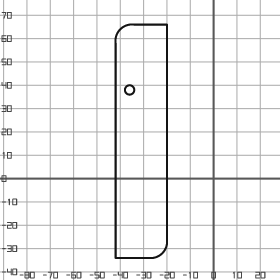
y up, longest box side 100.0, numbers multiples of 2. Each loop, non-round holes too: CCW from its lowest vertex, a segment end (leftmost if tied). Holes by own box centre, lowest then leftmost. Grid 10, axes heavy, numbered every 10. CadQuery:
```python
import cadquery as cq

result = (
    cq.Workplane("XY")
    .moveTo(-42.0, -34.0)
    .lineTo(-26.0, -34.0)
    .threePointArc((-22.0, -32.0), (-20.0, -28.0))
    .lineTo(-20.0, 66.0)
    .lineTo(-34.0, 66.0)
    .threePointArc((-40.0, 64.0), (-42.0, 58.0))
    .close()
    .moveTo(-36.0, 38.0)
    .circle(2.0)
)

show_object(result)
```